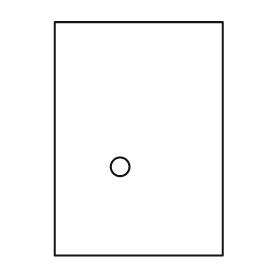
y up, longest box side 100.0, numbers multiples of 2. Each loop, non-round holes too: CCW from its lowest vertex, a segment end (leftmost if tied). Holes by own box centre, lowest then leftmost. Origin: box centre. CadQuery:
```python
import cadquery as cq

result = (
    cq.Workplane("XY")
    .moveTo(-36.0, -50.0)
    .lineTo(36.0, -50.0)
    .lineTo(36.0, 50.0)
    .lineTo(-36.0, 50.0)
    .close()
    .moveTo(-8.0, -12.0)
    .circle(4.0)
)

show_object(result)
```